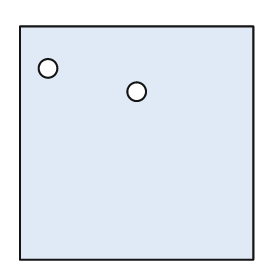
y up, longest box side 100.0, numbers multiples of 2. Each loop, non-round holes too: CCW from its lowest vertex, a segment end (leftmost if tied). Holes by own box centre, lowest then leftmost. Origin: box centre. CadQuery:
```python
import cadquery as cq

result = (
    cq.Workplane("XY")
    .moveTo(-50.0, -50.0)
    .lineTo(50.0, -50.0)
    .lineTo(50.0, 50.0)
    .lineTo(-50.0, 50.0)
    .close()
    .moveTo(0.0, 22.0)
    .circle(4.0)
    .moveTo(-38.0, 32.0)
    .circle(4.0)
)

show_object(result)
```